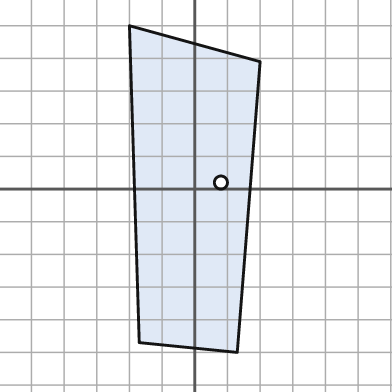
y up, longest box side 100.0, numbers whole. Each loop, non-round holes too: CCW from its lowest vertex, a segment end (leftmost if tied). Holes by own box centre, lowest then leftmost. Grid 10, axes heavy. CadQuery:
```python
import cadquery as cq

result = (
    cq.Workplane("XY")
    .moveTo(13.0, -50.0)
    .lineTo(20.0, 39.0)
    .lineTo(-20.0, 50.0)
    .lineTo(-17.0, -47.0)
    .close()
    .moveTo(8.0, 2.0)
    .circle(2.0)
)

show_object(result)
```